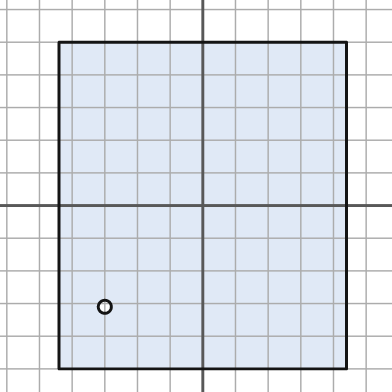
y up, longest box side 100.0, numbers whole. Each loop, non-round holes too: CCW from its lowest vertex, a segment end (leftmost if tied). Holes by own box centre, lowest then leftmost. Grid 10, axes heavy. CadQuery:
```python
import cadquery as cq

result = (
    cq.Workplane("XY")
    .moveTo(-44.0, -50.0)
    .lineTo(44.0, -50.0)
    .lineTo(44.0, 50.0)
    .lineTo(-44.0, 50.0)
    .close()
    .moveTo(-30.0, -31.0)
    .circle(2.0)
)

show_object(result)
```